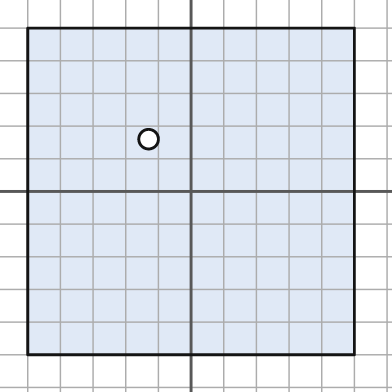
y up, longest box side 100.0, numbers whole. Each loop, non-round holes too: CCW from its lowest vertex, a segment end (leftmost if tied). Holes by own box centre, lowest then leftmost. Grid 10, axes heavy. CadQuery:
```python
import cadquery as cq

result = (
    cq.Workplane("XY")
    .moveTo(-50.0, -50.0)
    .lineTo(50.0, -50.0)
    .lineTo(50.0, 50.0)
    .lineTo(-50.0, 50.0)
    .close()
    .moveTo(-13.0, 16.0)
    .circle(3.0)
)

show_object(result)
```